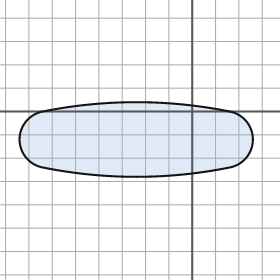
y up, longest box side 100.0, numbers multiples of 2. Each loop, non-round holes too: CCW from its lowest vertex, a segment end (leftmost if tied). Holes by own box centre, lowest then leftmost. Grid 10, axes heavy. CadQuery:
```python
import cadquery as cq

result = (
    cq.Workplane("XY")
    .moveTo(-64.0, -24.0)
    .threePointArc((-24.0, -28.0), (16.0, -24.0))
    .threePointArc((26.0, -12.0), (16.0, 0.0))
    .threePointArc((-24.0, 4.0), (-64.0, 0.0))
    .threePointArc((-74.0, -12.0), (-64.0, -24.0))
    .close()
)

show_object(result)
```